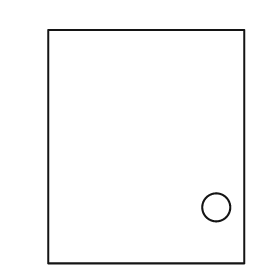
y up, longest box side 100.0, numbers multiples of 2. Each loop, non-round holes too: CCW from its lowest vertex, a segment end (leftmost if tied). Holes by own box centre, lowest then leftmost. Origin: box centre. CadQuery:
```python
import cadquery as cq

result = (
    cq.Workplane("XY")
    .moveTo(-42.0, -50.0)
    .lineTo(42.0, -50.0)
    .lineTo(42.0, 50.0)
    .lineTo(-42.0, 50.0)
    .close()
    .moveTo(30.0, -26.0)
    .circle(6.0)
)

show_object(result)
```